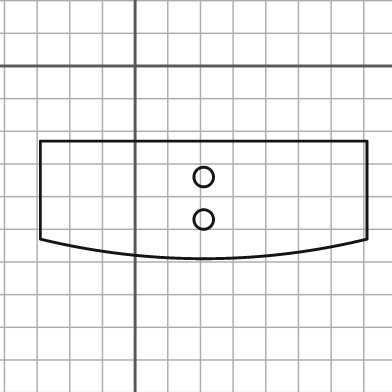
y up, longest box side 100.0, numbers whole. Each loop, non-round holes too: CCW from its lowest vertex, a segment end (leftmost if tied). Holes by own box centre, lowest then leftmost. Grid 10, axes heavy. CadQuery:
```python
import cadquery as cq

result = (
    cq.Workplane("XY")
    .moveTo(-29.0, -53.0)
    .threePointArc((21.0, -59.0), (71.0, -53.0))
    .lineTo(71.0, -23.0)
    .lineTo(-29.0, -23.0)
    .close()
    .moveTo(21.0, -47.0)
    .circle(3.0)
    .moveTo(21.0, -34.0)
    .circle(3.0)
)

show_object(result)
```